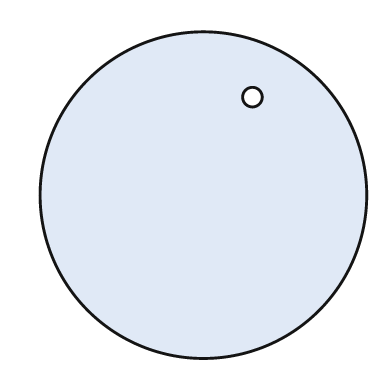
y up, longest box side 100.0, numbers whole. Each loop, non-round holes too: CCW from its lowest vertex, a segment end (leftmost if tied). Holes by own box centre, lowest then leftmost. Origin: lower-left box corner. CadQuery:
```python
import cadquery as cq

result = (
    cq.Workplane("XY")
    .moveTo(50.0, 50.0)
    .circle(50.0)
    .moveTo(65.0, 80.0)
    .circle(3.0)
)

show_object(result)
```